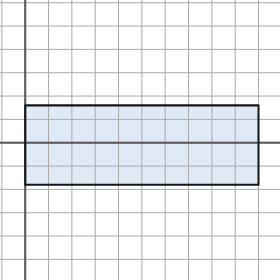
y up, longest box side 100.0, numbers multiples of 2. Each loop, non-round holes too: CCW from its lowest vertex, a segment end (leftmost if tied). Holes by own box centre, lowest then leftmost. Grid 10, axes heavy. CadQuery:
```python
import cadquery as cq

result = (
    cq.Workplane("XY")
    .moveTo(0.0, -18.0)
    .lineTo(100.0, -18.0)
    .lineTo(100.0, 16.0)
    .lineTo(0.0, 16.0)
    .close()
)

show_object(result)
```